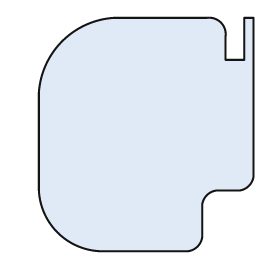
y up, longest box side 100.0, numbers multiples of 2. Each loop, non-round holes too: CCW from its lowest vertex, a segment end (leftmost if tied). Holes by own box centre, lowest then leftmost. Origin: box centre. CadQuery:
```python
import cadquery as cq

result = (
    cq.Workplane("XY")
    .moveTo(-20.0, -50.0)
    .lineTo(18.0, -50.0)
    .threePointArc((22.0, -48.0), (24.0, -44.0))
    .lineTo(24.0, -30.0)
    .threePointArc((26.0, -26.0), (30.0, -24.0))
    .lineTo(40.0, -24.0)
    .threePointArc((44.0, -22.0), (46.0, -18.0))
    .lineTo(46.0, 50.0)
    .lineTo(42.0, 50.0)
    .lineTo(42.0, 32.0)
    .lineTo(34.0, 32.0)
    .lineTo(34.0, 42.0)
    .threePointArc((32.0, 48.0), (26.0, 50.0))
    .lineTo(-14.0, 50.0)
    .threePointArc((-36.0, 40.0), (-46.0, 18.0))
    .lineTo(-46.0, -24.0)
    .threePointArc((-38.0, -42.0), (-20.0, -50.0))
    .close()
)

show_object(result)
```